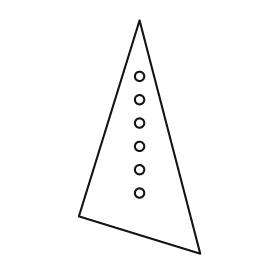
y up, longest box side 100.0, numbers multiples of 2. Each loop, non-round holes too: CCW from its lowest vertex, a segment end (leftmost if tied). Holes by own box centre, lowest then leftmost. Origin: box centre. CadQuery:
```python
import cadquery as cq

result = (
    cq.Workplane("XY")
    .moveTo(26.0, -50.0)
    .lineTo(0.0, 50.0)
    .lineTo(-26.0, -34.0)
    .close()
    .moveTo(0.0, -24.0)
    .circle(2.0)
    .moveTo(0.0, -14.0)
    .circle(2.0)
    .moveTo(0.0, -4.0)
    .circle(2.0)
    .moveTo(0.0, 6.0)
    .circle(2.0)
    .moveTo(0.0, 16.0)
    .circle(2.0)
    .moveTo(0.0, 26.0)
    .circle(2.0)
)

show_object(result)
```